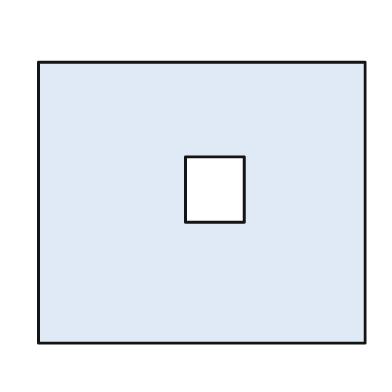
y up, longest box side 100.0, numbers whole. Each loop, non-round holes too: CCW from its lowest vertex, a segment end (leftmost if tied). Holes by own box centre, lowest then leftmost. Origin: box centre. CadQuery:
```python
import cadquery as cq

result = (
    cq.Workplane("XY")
    .moveTo(-50.0, -43.0)
    .lineTo(50.0, -43.0)
    .lineTo(50.0, 43.0)
    .lineTo(-50.0, 43.0)
    .close()
    .moveTo(-5.0, -6.0)
    .lineTo(13.0, -6.0)
    .lineTo(13.0, 14.0)
    .lineTo(-5.0, 14.0)
    .close()
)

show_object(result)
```